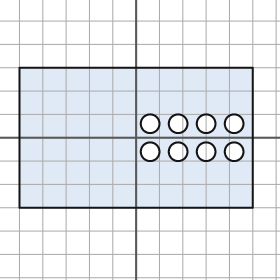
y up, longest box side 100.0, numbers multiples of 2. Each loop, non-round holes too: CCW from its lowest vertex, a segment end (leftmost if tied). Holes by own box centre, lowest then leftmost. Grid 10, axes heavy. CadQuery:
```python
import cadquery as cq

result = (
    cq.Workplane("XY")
    .moveTo(-50.0, -30.0)
    .lineTo(50.0, -30.0)
    .lineTo(50.0, 30.0)
    .lineTo(-50.0, 30.0)
    .close()
    .moveTo(6.0, -6.0)
    .circle(4.0)
    .moveTo(18.0, -6.0)
    .circle(4.0)
    .moveTo(30.0, -6.0)
    .circle(4.0)
    .moveTo(42.0, -6.0)
    .circle(4.0)
    .moveTo(6.0, 6.0)
    .circle(4.0)
    .moveTo(18.0, 6.0)
    .circle(4.0)
    .moveTo(30.0, 6.0)
    .circle(4.0)
    .moveTo(42.0, 6.0)
    .circle(4.0)
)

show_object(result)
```